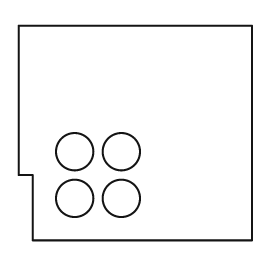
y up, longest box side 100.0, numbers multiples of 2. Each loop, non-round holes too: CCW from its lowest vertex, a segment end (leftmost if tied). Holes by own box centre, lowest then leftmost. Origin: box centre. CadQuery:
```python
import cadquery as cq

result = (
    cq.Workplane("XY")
    .moveTo(-44.0, -46.0)
    .lineTo(50.0, -46.0)
    .lineTo(50.0, 46.0)
    .lineTo(-50.0, 46.0)
    .lineTo(-50.0, -18.0)
    .lineTo(-44.0, -18.0)
    .close()
    .moveTo(-26.0, -28.0)
    .circle(8.0)
    .moveTo(-6.0, -28.0)
    .circle(8.0)
    .moveTo(-26.0, -8.0)
    .circle(8.0)
    .moveTo(-6.0, -8.0)
    .circle(8.0)
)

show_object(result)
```